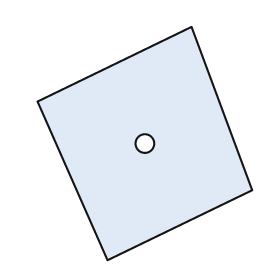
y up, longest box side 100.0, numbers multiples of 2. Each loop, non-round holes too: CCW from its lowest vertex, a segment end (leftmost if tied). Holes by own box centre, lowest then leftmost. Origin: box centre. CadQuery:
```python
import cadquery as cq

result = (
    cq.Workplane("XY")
    .moveTo(-16.0, -50.0)
    .lineTo(46.0, -20.0)
    .lineTo(20.0, 50.0)
    .lineTo(-46.0, 18.0)
    .close()
    .moveTo(0.0, 0.0)
    .circle(4.0)
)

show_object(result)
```